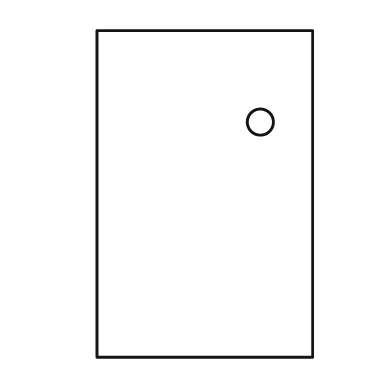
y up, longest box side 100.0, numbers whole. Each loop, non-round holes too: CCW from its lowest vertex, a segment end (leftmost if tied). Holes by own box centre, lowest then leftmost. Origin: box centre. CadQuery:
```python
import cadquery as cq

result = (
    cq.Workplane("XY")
    .moveTo(-33.0, -50.0)
    .lineTo(33.0, -50.0)
    .lineTo(33.0, 50.0)
    .lineTo(-33.0, 50.0)
    .close()
    .moveTo(17.0, 22.0)
    .circle(4.0)
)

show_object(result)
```